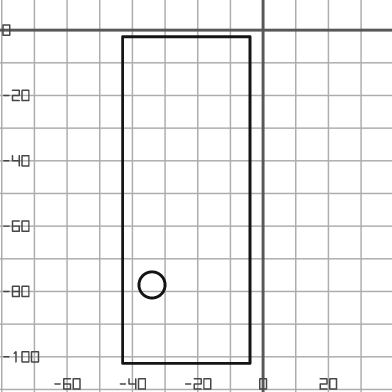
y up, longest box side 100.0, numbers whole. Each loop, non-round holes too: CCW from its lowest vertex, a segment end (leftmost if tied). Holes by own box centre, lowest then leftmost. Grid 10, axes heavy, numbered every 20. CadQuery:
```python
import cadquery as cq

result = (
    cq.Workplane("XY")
    .moveTo(-43.0, -102.0)
    .lineTo(-4.0, -102.0)
    .lineTo(-4.0, -2.0)
    .lineTo(-43.0, -2.0)
    .close()
    .moveTo(-34.0, -78.0)
    .circle(4.0)
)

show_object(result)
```